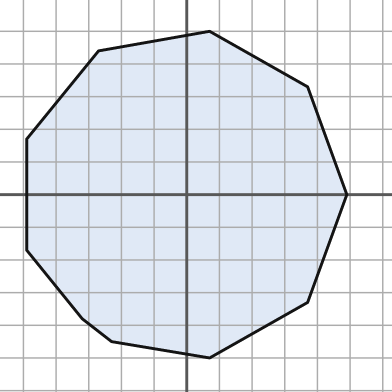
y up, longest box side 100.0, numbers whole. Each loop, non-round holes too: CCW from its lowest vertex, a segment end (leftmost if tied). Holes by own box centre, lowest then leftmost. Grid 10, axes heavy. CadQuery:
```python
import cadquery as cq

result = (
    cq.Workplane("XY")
    .moveTo(7.0, -50.0)
    .lineTo(37.0, -33.0)
    .lineTo(49.0, 0.0)
    .lineTo(37.0, 33.0)
    .lineTo(7.0, 50.0)
    .lineTo(-27.0, 44.0)
    .lineTo(-49.0, 17.0)
    .lineTo(-49.0, -17.0)
    .lineTo(-32.0, -38.0)
    .lineTo(-23.0, -45.0)
    .close()
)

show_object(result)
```